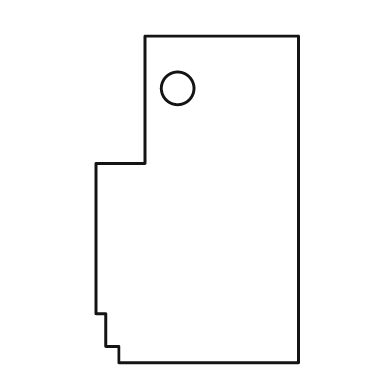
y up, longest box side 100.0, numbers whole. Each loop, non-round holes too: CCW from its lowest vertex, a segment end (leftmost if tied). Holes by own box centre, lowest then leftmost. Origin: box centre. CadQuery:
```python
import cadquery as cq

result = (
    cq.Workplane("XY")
    .moveTo(-24.0, -50.0)
    .lineTo(31.0, -50.0)
    .lineTo(31.0, 50.0)
    .lineTo(-16.0, 50.0)
    .lineTo(-16.0, 11.0)
    .lineTo(-31.0, 11.0)
    .lineTo(-31.0, -35.0)
    .lineTo(-28.0, -35.0)
    .lineTo(-28.0, -45.0)
    .lineTo(-24.0, -45.0)
    .close()
    .moveTo(-6.0, 34.0)
    .circle(5.0)
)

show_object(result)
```